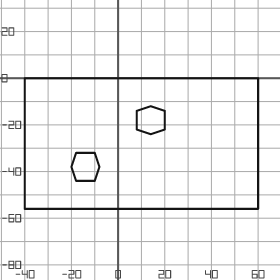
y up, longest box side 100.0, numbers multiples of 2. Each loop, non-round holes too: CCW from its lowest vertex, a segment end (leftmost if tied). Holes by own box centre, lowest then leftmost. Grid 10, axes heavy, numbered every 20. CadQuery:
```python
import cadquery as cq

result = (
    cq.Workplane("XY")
    .moveTo(-40.0, -56.0)
    .lineTo(60.0, -56.0)
    .lineTo(60.0, 0.0)
    .lineTo(-40.0, 0.0)
    .close()
    .moveTo(-18.0, -44.0)
    .lineTo(-10.0, -44.0)
    .lineTo(-8.0, -38.0)
    .lineTo(-10.0, -32.0)
    .lineTo(-18.0, -32.0)
    .lineTo(-20.0, -38.0)
    .close()
    .moveTo(14.0, -24.0)
    .lineTo(20.0, -22.0)
    .lineTo(20.0, -14.0)
    .lineTo(14.0, -12.0)
    .lineTo(8.0, -14.0)
    .lineTo(8.0, -22.0)
    .close()
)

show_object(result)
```